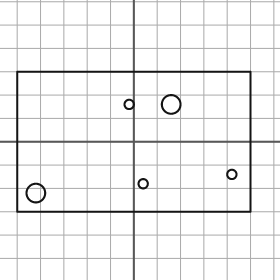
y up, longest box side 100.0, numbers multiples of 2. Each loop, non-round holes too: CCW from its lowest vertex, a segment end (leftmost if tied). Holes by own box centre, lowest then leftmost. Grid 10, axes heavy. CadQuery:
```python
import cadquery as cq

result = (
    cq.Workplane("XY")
    .moveTo(-50.0, -30.0)
    .lineTo(50.0, -30.0)
    .lineTo(50.0, 30.0)
    .lineTo(-50.0, 30.0)
    .close()
    .moveTo(-42.0, -22.0)
    .circle(4.0)
    .moveTo(4.0, -18.0)
    .circle(2.0)
    .moveTo(42.0, -14.0)
    .circle(2.0)
    .moveTo(-2.0, 16.0)
    .circle(2.0)
    .moveTo(16.0, 16.0)
    .circle(4.0)
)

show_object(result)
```